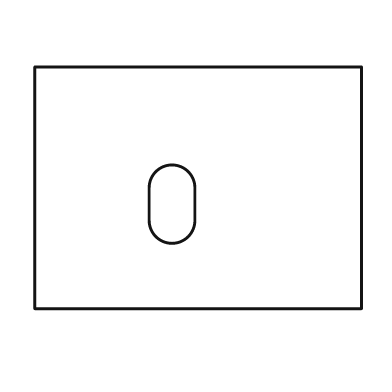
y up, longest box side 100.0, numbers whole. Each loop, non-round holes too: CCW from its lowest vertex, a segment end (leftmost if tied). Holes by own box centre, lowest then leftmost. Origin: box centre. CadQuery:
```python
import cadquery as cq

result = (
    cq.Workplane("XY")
    .moveTo(-50.0, -37.0)
    .lineTo(50.0, -37.0)
    .lineTo(50.0, 37.0)
    .lineTo(-50.0, 37.0)
    .close()
    .moveTo(-15.0, -10.0)
    .threePointArc((-8.0, -17.0), (-1.0, -10.0))
    .lineTo(-1.0, 0.0)
    .threePointArc((-8.0, 7.0), (-15.0, 0.0))
    .close()
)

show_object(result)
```